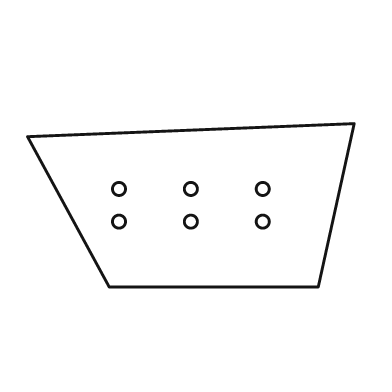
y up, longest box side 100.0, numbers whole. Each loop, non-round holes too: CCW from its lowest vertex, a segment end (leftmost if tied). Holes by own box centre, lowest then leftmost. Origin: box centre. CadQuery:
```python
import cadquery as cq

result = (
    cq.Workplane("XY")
    .moveTo(-25.0, -25.0)
    .lineTo(39.0, -25.0)
    .lineTo(50.0, 25.0)
    .lineTo(-50.0, 21.0)
    .close()
    .moveTo(-22.0, -5.0)
    .circle(2.0)
    .moveTo(0.0, -5.0)
    .circle(2.0)
    .moveTo(22.0, -5.0)
    .circle(2.0)
    .moveTo(-22.0, 5.0)
    .circle(2.0)
    .moveTo(0.0, 5.0)
    .circle(2.0)
    .moveTo(22.0, 5.0)
    .circle(2.0)
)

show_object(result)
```